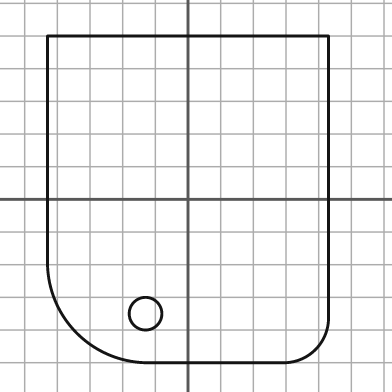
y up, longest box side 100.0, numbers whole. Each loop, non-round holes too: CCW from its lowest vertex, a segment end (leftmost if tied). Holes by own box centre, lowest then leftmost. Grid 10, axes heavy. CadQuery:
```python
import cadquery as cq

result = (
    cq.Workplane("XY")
    .moveTo(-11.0, -50.0)
    .lineTo(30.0, -50.0)
    .threePointArc((39.0, -46.0), (43.0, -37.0))
    .lineTo(43.0, 50.0)
    .lineTo(-43.0, 50.0)
    .lineTo(-43.0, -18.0)
    .threePointArc((-34.0, -41.0), (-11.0, -50.0))
    .close()
    .moveTo(-13.0, -35.0)
    .circle(5.0)
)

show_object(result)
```